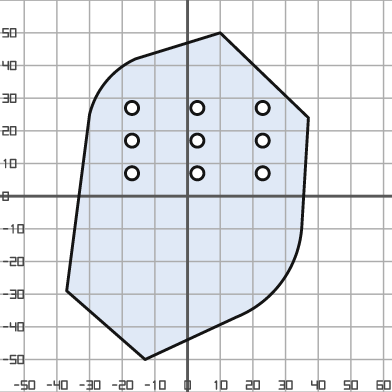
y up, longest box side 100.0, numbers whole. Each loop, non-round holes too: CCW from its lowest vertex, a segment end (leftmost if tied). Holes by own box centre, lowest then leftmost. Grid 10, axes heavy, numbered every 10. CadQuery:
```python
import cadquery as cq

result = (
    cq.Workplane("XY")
    .moveTo(-13.0, -50.0)
    .lineTo(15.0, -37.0)
    .threePointArc((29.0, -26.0), (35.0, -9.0))
    .lineTo(37.0, 24.0)
    .lineTo(10.0, 50.0)
    .lineTo(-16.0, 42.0)
    .threePointArc((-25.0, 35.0), (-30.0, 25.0))
    .lineTo(-37.0, -29.0)
    .close()
    .moveTo(-17.0, 7.0)
    .circle(2.0)
    .moveTo(3.0, 7.0)
    .circle(2.0)
    .moveTo(23.0, 7.0)
    .circle(2.0)
    .moveTo(-17.0, 17.0)
    .circle(2.0)
    .moveTo(3.0, 17.0)
    .circle(2.0)
    .moveTo(23.0, 17.0)
    .circle(2.0)
    .moveTo(-17.0, 27.0)
    .circle(2.0)
    .moveTo(3.0, 27.0)
    .circle(2.0)
    .moveTo(23.0, 27.0)
    .circle(2.0)
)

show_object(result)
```